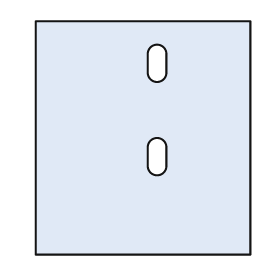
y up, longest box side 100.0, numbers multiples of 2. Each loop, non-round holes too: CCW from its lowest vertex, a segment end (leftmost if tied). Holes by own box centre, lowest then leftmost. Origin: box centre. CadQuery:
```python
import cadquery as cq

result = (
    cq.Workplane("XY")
    .moveTo(-46.0, -50.0)
    .lineTo(46.0, -50.0)
    .lineTo(46.0, 50.0)
    .lineTo(-46.0, 50.0)
    .close()
    .moveTo(2.0, -12.0)
    .threePointArc((6.0, -16.0), (10.0, -12.0))
    .lineTo(10.0, -4.0)
    .threePointArc((6.0, 0.0), (2.0, -4.0))
    .close()
    .moveTo(2.0, 28.0)
    .threePointArc((6.0, 24.0), (10.0, 28.0))
    .lineTo(10.0, 36.0)
    .threePointArc((6.0, 40.0), (2.0, 36.0))
    .close()
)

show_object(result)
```